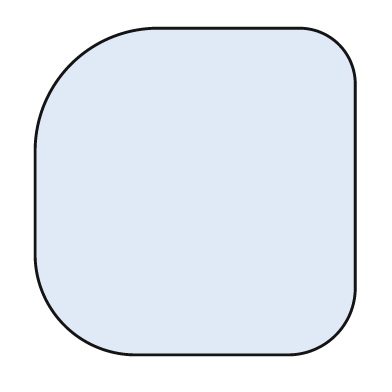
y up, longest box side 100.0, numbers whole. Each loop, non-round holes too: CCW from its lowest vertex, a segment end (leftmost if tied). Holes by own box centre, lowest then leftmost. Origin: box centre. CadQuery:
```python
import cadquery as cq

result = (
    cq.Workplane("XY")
    .moveTo(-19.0, -50.0)
    .lineTo(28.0, -50.0)
    .threePointArc((43.0, -44.0), (49.0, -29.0))
    .lineTo(49.0, 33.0)
    .threePointArc((44.0, 45.0), (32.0, 50.0))
    .lineTo(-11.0, 50.0)
    .threePointArc((-38.0, 39.0), (-49.0, 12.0))
    .lineTo(-49.0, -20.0)
    .threePointArc((-40.0, -41.0), (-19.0, -50.0))
    .close()
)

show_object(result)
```